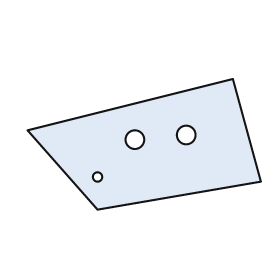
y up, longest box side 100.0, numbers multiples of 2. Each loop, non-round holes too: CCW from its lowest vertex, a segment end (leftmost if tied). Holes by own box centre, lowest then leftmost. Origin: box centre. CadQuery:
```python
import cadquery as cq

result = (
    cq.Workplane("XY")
    .moveTo(-20.0, -28.0)
    .lineTo(50.0, -16.0)
    .lineTo(38.0, 28.0)
    .lineTo(-50.0, 6.0)
    .close()
    .moveTo(-20.0, -14.0)
    .circle(2.0)
    .moveTo(-4.0, 2.0)
    .circle(4.0)
    .moveTo(18.0, 4.0)
    .circle(4.0)
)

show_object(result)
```